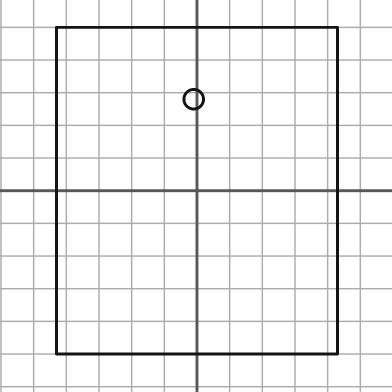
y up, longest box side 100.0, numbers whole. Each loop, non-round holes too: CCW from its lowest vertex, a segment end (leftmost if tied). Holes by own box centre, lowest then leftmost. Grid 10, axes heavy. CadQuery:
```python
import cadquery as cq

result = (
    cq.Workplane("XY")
    .moveTo(-43.0, -50.0)
    .lineTo(43.0, -50.0)
    .lineTo(43.0, 50.0)
    .lineTo(-43.0, 50.0)
    .close()
    .moveTo(-1.0, 28.0)
    .circle(3.0)
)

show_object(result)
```